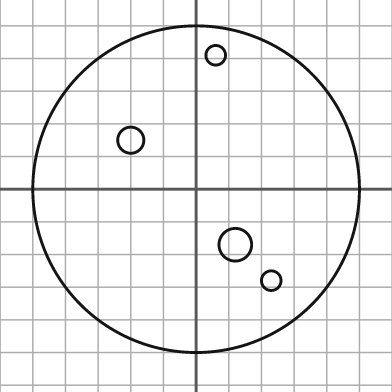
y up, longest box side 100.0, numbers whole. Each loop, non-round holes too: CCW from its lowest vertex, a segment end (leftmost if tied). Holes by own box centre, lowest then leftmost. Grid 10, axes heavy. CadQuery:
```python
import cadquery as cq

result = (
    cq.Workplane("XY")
    .moveTo(0.0, 0.0)
    .circle(50.0)
    .moveTo(23.0, -28.0)
    .circle(3.0)
    .moveTo(12.0, -17.0)
    .circle(5.0)
    .moveTo(-20.0, 15.0)
    .circle(4.0)
    .moveTo(6.0, 41.0)
    .circle(3.0)
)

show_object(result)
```